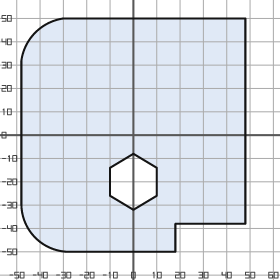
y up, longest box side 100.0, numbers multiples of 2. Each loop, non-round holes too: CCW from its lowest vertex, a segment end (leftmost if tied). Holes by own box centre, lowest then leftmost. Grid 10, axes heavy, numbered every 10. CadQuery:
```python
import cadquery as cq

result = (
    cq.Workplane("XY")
    .moveTo(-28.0, -50.0)
    .lineTo(18.0, -50.0)
    .lineTo(18.0, -38.0)
    .lineTo(48.0, -38.0)
    .lineTo(48.0, 50.0)
    .lineTo(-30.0, 50.0)
    .threePointArc((-42.0, 44.0), (-48.0, 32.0))
    .lineTo(-48.0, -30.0)
    .threePointArc((-42.0, -44.0), (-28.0, -50.0))
    .close()
    .moveTo(0.0, -32.0)
    .lineTo(10.0, -26.0)
    .lineTo(10.0, -14.0)
    .lineTo(0.0, -8.0)
    .lineTo(-10.0, -14.0)
    .lineTo(-10.0, -26.0)
    .close()
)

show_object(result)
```